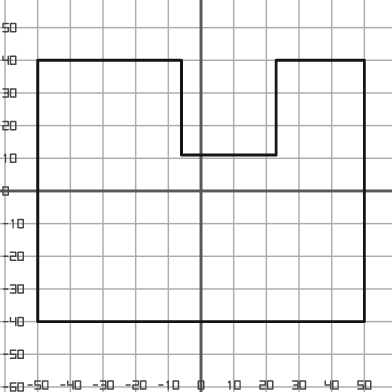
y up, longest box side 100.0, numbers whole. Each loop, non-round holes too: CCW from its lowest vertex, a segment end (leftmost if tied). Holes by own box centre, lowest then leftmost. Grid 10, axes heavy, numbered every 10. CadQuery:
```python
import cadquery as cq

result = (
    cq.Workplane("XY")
    .moveTo(-50.0, -40.0)
    .lineTo(50.0, -40.0)
    .lineTo(50.0, 40.0)
    .lineTo(23.0, 40.0)
    .lineTo(23.0, 11.0)
    .lineTo(-6.0, 11.0)
    .lineTo(-6.0, 40.0)
    .lineTo(-50.0, 40.0)
    .close()
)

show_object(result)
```